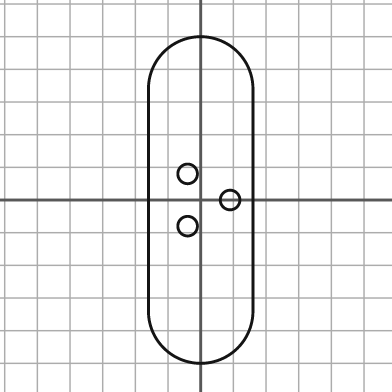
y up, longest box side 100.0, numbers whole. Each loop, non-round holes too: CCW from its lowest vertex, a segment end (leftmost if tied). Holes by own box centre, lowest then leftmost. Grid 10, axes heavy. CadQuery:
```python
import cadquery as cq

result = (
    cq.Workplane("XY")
    .moveTo(-16.0, -34.0)
    .threePointArc((0.0, -50.0), (16.0, -34.0))
    .lineTo(16.0, 34.0)
    .threePointArc((0.0, 50.0), (-16.0, 34.0))
    .close()
    .moveTo(-4.0, -8.0)
    .circle(3.0)
    .moveTo(9.0, 0.0)
    .circle(3.0)
    .moveTo(-4.0, 8.0)
    .circle(3.0)
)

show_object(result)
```